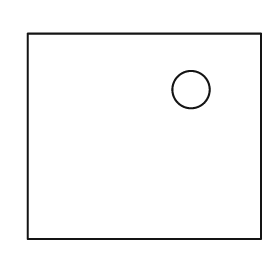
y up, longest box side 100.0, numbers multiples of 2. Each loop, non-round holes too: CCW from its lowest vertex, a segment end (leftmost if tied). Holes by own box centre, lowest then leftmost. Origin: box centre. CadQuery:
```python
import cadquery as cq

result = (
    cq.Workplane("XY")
    .moveTo(-50.0, -44.0)
    .lineTo(50.0, -44.0)
    .lineTo(50.0, 44.0)
    .lineTo(-50.0, 44.0)
    .close()
    .moveTo(20.0, 20.0)
    .circle(8.0)
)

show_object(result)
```